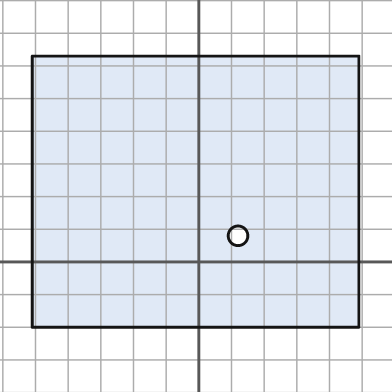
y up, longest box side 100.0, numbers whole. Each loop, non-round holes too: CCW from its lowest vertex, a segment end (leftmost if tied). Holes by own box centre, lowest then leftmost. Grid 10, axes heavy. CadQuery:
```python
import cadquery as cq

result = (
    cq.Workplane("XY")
    .moveTo(-51.0, -20.0)
    .lineTo(49.0, -20.0)
    .lineTo(49.0, 63.0)
    .lineTo(-51.0, 63.0)
    .close()
    .moveTo(12.0, 8.0)
    .circle(3.0)
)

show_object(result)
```